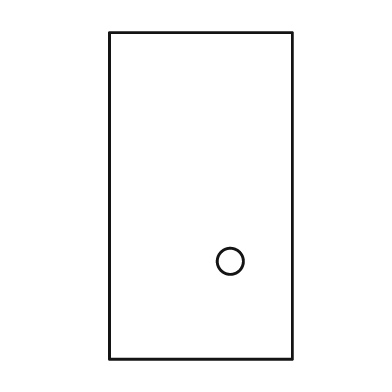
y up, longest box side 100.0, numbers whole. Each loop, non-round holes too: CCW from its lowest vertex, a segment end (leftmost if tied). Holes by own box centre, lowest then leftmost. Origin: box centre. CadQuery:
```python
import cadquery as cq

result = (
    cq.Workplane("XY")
    .moveTo(-28.0, -50.0)
    .lineTo(28.0, -50.0)
    .lineTo(28.0, 50.0)
    .lineTo(-28.0, 50.0)
    .close()
    .moveTo(9.0, -20.0)
    .circle(4.0)
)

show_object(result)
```